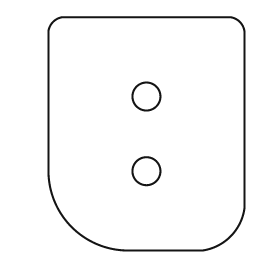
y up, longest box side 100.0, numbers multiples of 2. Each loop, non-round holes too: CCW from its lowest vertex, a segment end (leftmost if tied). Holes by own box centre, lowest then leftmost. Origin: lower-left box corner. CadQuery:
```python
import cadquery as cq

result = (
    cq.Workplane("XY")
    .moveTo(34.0, 0.0)
    .lineTo(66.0, 0.0)
    .threePointArc((78.0, 6.0), (84.0, 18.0))
    .lineTo(84.0, 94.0)
    .threePointArc((82.0, 98.0), (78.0, 100.0))
    .lineTo(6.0, 100.0)
    .threePointArc((2.0, 98.0), (0.0, 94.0))
    .lineTo(0.0, 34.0)
    .threePointArc((10.0, 10.0), (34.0, 0.0))
    .close()
    .moveTo(42.0, 34.0)
    .circle(6.0)
    .moveTo(42.0, 66.0)
    .circle(6.0)
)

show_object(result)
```